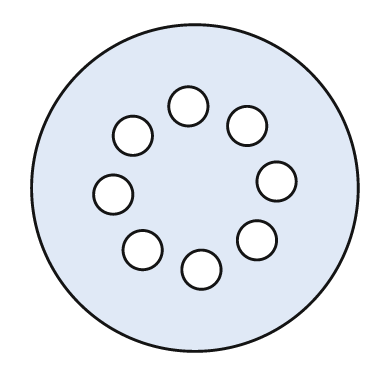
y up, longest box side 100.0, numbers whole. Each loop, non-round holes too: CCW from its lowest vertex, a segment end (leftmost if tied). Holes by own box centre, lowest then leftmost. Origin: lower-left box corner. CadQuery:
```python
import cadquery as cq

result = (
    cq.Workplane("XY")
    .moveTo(50.0, 50.0)
    .circle(50.0)
    .moveTo(52.0, 25.0)
    .circle(6.0)
    .moveTo(34.0, 31.0)
    .circle(6.0)
    .moveTo(69.0, 34.0)
    .circle(6.0)
    .moveTo(25.0, 48.0)
    .circle(6.0)
    .moveTo(75.0, 52.0)
    .circle(6.0)
    .moveTo(31.0, 66.0)
    .circle(6.0)
    .moveTo(66.0, 69.0)
    .circle(6.0)
    .moveTo(48.0, 75.0)
    .circle(6.0)
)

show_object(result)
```